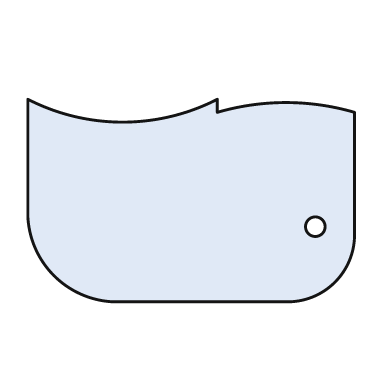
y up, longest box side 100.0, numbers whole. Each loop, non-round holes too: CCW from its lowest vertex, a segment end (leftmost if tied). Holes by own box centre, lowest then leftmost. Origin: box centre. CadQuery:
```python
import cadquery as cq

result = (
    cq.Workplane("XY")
    .moveTo(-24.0, -31.0)
    .lineTo(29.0, -31.0)
    .threePointArc((44.0, -25.0), (50.0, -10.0))
    .lineTo(50.0, 27.0)
    .threePointArc((29.0, 30.0), (8.0, 27.0))
    .lineTo(8.0, 31.0)
    .threePointArc((-21.0, 24.0), (-50.0, 31.0))
    .lineTo(-50.0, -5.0)
    .threePointArc((-42.0, -23.0), (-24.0, -31.0))
    .close()
    .moveTo(38.0, -8.0)
    .circle(3.0)
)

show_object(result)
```